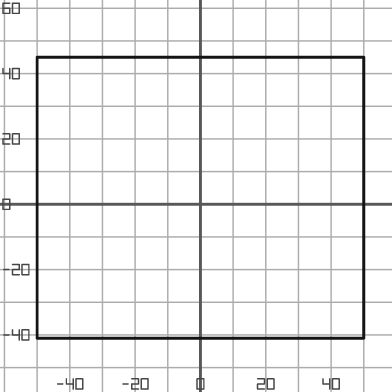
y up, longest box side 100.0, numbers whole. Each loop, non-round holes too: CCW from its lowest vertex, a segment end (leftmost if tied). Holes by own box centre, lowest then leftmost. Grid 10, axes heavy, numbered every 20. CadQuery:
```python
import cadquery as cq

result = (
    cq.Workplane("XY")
    .moveTo(-50.0, -41.0)
    .lineTo(50.0, -41.0)
    .lineTo(50.0, 45.0)
    .lineTo(-50.0, 45.0)
    .close()
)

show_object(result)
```